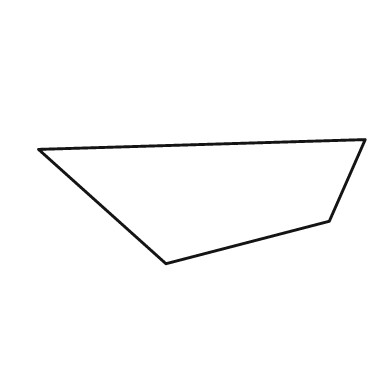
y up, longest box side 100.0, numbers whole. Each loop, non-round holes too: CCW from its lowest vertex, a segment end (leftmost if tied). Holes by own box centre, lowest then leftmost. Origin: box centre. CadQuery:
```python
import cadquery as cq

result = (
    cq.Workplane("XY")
    .moveTo(-11.0, -19.0)
    .lineTo(39.0, -6.0)
    .lineTo(50.0, 19.0)
    .lineTo(-50.0, 16.0)
    .close()
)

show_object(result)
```